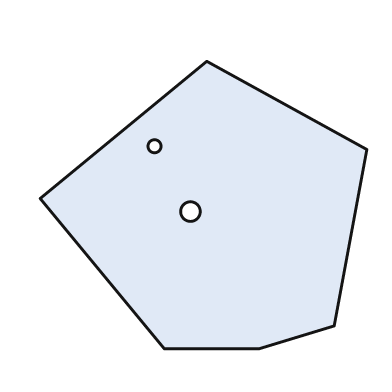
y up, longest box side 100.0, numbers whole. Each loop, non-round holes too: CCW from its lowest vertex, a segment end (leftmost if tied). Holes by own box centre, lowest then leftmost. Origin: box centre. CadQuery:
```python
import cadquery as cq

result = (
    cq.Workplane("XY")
    .moveTo(-12.0, -44.0)
    .lineTo(17.0, -44.0)
    .lineTo(40.0, -37.0)
    .lineTo(50.0, 17.0)
    .lineTo(1.0, 44.0)
    .lineTo(-50.0, 2.0)
    .close()
    .moveTo(-4.0, -2.0)
    .circle(3.0)
    .moveTo(-15.0, 18.0)
    .circle(2.0)
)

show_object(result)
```